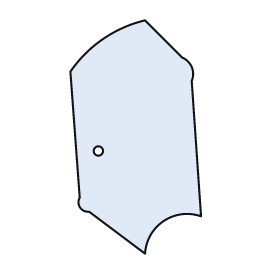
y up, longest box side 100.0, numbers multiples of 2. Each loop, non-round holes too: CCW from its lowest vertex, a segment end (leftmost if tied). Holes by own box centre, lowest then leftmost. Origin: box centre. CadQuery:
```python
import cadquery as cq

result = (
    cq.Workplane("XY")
    .moveTo(4.0, -50.0)
    .threePointArc((12.0, -36.0), (28.0, -34.0))
    .lineTo(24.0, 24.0)
    .threePointArc((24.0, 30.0), (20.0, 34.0))
    .lineTo(4.0, 50.0)
    .threePointArc((-14.0, 42.0), (-28.0, 28.0))
    .lineTo(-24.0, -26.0)
    .threePointArc((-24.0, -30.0), (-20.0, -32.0))
    .close()
    .moveTo(-16.0, -6.0)
    .circle(2.0)
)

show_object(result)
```